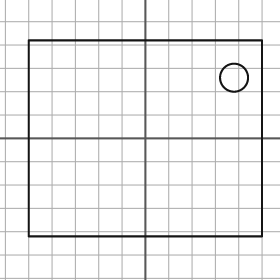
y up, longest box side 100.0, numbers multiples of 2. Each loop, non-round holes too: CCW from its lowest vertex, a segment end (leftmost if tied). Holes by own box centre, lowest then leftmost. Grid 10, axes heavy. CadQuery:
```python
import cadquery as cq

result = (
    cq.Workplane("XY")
    .moveTo(-50.0, -42.0)
    .lineTo(50.0, -42.0)
    .lineTo(50.0, 42.0)
    .lineTo(-50.0, 42.0)
    .close()
    .moveTo(38.0, 26.0)
    .circle(6.0)
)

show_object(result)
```